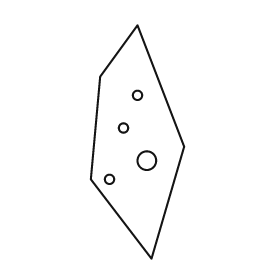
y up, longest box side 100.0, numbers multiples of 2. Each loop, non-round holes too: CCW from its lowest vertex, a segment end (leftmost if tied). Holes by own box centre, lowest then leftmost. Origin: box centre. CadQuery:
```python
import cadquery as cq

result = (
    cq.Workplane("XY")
    .moveTo(6.0, -50.0)
    .lineTo(20.0, -2.0)
    .lineTo(0.0, 50.0)
    .lineTo(-16.0, 28.0)
    .lineTo(-20.0, -16.0)
    .close()
    .moveTo(-12.0, -16.0)
    .circle(2.0)
    .moveTo(4.0, -8.0)
    .circle(4.0)
    .moveTo(-6.0, 6.0)
    .circle(2.0)
    .moveTo(0.0, 20.0)
    .circle(2.0)
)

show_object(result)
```